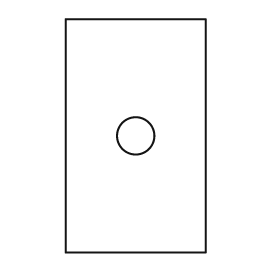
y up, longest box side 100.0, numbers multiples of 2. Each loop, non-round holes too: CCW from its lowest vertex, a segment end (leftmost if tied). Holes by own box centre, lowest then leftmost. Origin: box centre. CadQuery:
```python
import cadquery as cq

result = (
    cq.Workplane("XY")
    .moveTo(-30.0, -50.0)
    .lineTo(30.0, -50.0)
    .lineTo(30.0, 50.0)
    .lineTo(-30.0, 50.0)
    .close()
    .moveTo(0.0, 0.0)
    .circle(8.0)
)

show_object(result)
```